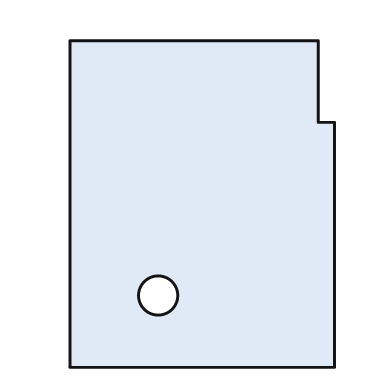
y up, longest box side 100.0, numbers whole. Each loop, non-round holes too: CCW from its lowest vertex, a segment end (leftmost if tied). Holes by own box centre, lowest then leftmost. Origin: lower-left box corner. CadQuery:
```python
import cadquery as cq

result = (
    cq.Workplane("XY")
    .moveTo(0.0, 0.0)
    .lineTo(81.0, 0.0)
    .lineTo(81.0, 75.0)
    .lineTo(76.0, 75.0)
    .lineTo(76.0, 100.0)
    .lineTo(0.0, 100.0)
    .close()
    .moveTo(27.0, 22.0)
    .circle(6.0)
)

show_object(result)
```